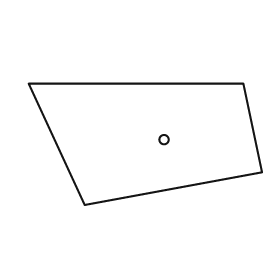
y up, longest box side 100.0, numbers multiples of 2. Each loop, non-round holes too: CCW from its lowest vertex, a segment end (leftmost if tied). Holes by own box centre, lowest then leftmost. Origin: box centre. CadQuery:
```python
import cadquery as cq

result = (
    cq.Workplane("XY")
    .moveTo(-26.0, -26.0)
    .lineTo(50.0, -12.0)
    .lineTo(42.0, 26.0)
    .lineTo(-50.0, 26.0)
    .close()
    .moveTo(8.0, 2.0)
    .circle(2.0)
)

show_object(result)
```